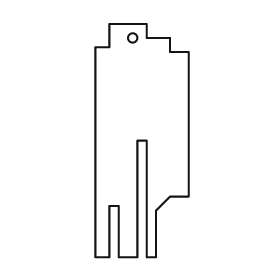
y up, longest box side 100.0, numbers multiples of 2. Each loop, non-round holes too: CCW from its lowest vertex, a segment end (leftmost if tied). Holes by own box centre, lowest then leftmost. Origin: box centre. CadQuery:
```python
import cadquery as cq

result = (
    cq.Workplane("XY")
    .moveTo(-20.0, -50.0)
    .lineTo(-14.0, -50.0)
    .lineTo(-14.0, -28.0)
    .lineTo(-10.0, -28.0)
    .lineTo(-10.0, -50.0)
    .lineTo(-2.0, -50.0)
    .lineTo(-2.0, 0.0)
    .lineTo(2.0, 0.0)
    .lineTo(2.0, -50.0)
    .lineTo(6.0, -50.0)
    .lineTo(6.0, -30.0)
    .lineTo(12.0, -24.0)
    .lineTo(20.0, -24.0)
    .lineTo(20.0, 38.0)
    .lineTo(12.0, 38.0)
    .lineTo(12.0, 44.0)
    .lineTo(2.0, 44.0)
    .lineTo(2.0, 50.0)
    .lineTo(-14.0, 50.0)
    .lineTo(-14.0, 40.0)
    .lineTo(-20.0, 40.0)
    .close()
    .moveTo(-4.0, 44.0)
    .circle(2.0)
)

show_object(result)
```